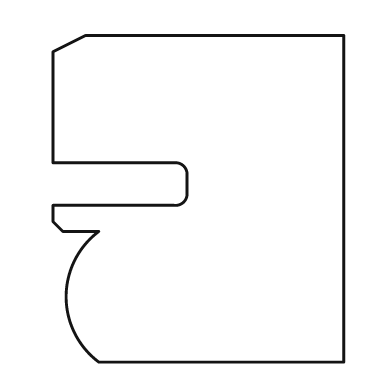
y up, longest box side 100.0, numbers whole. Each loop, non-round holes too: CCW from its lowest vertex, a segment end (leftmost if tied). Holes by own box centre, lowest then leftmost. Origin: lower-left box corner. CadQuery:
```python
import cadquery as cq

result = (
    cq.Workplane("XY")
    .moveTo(14.0, 0.0)
    .lineTo(89.0, 0.0)
    .lineTo(89.0, 100.0)
    .lineTo(10.0, 100.0)
    .lineTo(0.0, 95.0)
    .lineTo(0.0, 61.0)
    .lineTo(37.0, 61.0)
    .threePointArc((40.0, 60.0), (41.0, 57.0))
    .lineTo(41.0, 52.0)
    .threePointArc((40.0, 49.0), (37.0, 48.0))
    .lineTo(0.0, 48.0)
    .lineTo(0.0, 43.0)
    .lineTo(3.0, 40.0)
    .lineTo(14.0, 40.0)
    .threePointArc((4.0, 20.0), (14.0, 0.0))
    .close()
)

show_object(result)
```